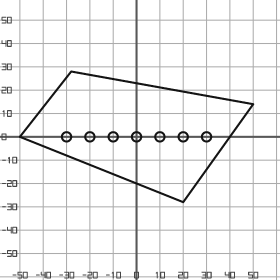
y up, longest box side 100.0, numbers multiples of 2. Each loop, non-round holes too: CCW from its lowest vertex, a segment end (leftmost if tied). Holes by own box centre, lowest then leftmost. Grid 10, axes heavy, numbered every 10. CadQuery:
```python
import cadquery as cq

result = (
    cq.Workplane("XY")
    .moveTo(20.0, -28.0)
    .lineTo(50.0, 14.0)
    .lineTo(-28.0, 28.0)
    .lineTo(-50.0, 0.0)
    .close()
    .moveTo(-30.0, 0.0)
    .circle(2.0)
    .moveTo(-20.0, 0.0)
    .circle(2.0)
    .moveTo(-10.0, 0.0)
    .circle(2.0)
    .moveTo(0.0, 0.0)
    .circle(2.0)
    .moveTo(10.0, 0.0)
    .circle(2.0)
    .moveTo(20.0, 0.0)
    .circle(2.0)
    .moveTo(30.0, 0.0)
    .circle(2.0)
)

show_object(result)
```